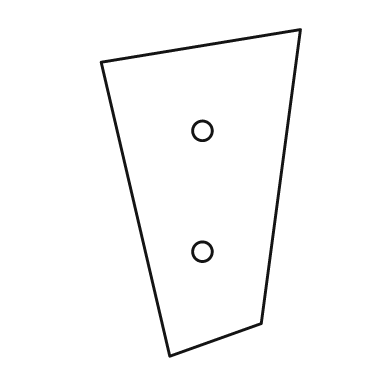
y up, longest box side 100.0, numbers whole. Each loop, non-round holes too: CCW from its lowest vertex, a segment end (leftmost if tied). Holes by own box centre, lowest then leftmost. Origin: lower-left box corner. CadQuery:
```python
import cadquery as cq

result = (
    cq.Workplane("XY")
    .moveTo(21.0, 0.0)
    .lineTo(49.0, 10.0)
    .lineTo(61.0, 100.0)
    .lineTo(0.0, 90.0)
    .close()
    .moveTo(31.0, 32.0)
    .circle(3.0)
    .moveTo(31.0, 69.0)
    .circle(3.0)
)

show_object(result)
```